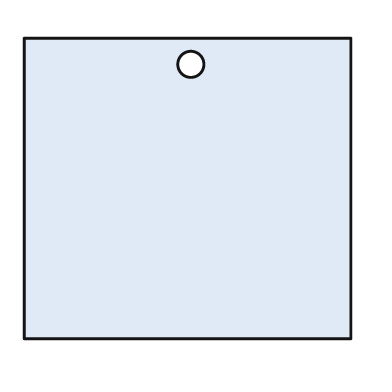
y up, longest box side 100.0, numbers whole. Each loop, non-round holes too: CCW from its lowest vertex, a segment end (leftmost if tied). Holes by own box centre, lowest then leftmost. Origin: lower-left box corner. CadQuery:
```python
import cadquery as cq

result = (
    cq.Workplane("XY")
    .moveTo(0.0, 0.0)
    .lineTo(100.0, 0.0)
    .lineTo(100.0, 92.0)
    .lineTo(0.0, 92.0)
    .close()
    .moveTo(51.0, 84.0)
    .circle(4.0)
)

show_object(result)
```